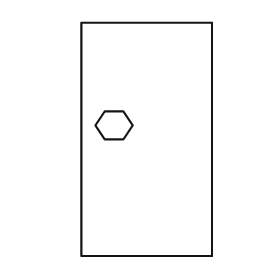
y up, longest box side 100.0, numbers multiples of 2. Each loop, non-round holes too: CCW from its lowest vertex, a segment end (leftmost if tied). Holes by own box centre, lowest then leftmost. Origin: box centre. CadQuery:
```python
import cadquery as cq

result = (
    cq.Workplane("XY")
    .moveTo(-28.0, -50.0)
    .lineTo(28.0, -50.0)
    .lineTo(28.0, 50.0)
    .lineTo(-28.0, 50.0)
    .close()
    .moveTo(-18.0, 0.0)
    .lineTo(-10.0, 0.0)
    .lineTo(-6.0, 6.0)
    .lineTo(-10.0, 12.0)
    .lineTo(-18.0, 12.0)
    .lineTo(-22.0, 6.0)
    .close()
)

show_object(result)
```